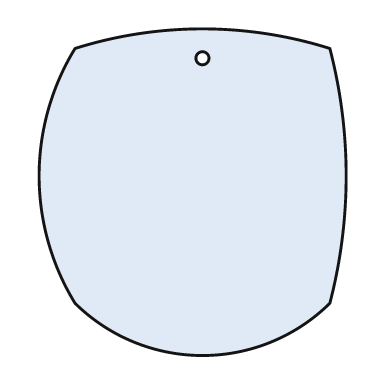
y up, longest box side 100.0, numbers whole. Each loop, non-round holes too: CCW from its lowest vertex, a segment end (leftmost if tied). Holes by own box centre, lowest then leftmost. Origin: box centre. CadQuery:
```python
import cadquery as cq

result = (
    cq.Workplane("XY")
    .moveTo(-36.0, -34.0)
    .threePointArc((3.0, -50.0), (42.0, -34.0))
    .threePointArc((47.0, 5.0), (42.0, 44.0))
    .threePointArc((3.0, 50.0), (-36.0, 44.0))
    .threePointArc((-47.0, 5.0), (-36.0, -34.0))
    .close()
    .moveTo(3.0, 41.0)
    .circle(2.0)
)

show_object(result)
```